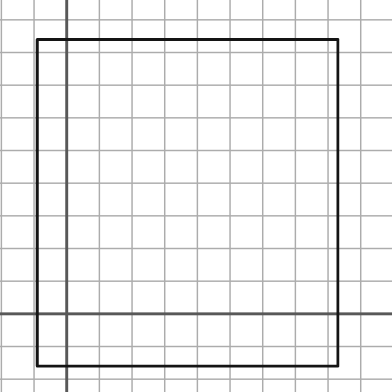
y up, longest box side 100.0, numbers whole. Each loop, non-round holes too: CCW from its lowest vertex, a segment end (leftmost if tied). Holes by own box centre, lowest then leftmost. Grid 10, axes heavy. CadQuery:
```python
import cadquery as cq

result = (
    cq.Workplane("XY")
    .moveTo(-9.0, -16.0)
    .lineTo(83.0, -16.0)
    .lineTo(83.0, 84.0)
    .lineTo(-9.0, 84.0)
    .close()
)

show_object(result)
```